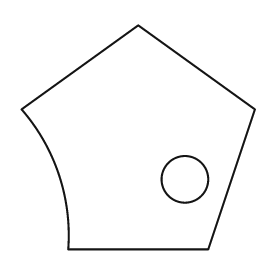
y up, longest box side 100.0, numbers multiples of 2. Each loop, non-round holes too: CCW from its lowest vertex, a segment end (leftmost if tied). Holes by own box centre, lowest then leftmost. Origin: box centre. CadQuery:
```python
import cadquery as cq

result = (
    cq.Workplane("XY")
    .moveTo(-30.0, -48.0)
    .lineTo(30.0, -48.0)
    .lineTo(50.0, 12.0)
    .lineTo(0.0, 48.0)
    .lineTo(-50.0, 12.0)
    .threePointArc((-34.0, -16.0), (-30.0, -48.0))
    .close()
    .moveTo(20.0, -18.0)
    .circle(10.0)
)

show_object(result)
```